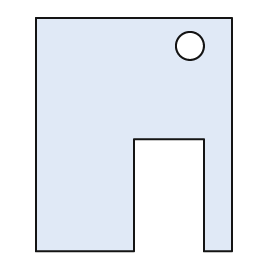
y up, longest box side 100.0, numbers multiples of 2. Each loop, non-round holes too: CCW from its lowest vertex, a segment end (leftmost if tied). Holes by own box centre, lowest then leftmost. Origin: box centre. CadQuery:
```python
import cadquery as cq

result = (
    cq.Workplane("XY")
    .moveTo(-42.0, -50.0)
    .lineTo(0.0, -50.0)
    .lineTo(0.0, -2.0)
    .lineTo(30.0, -2.0)
    .lineTo(30.0, -50.0)
    .lineTo(42.0, -50.0)
    .lineTo(42.0, 50.0)
    .lineTo(-42.0, 50.0)
    .close()
    .moveTo(24.0, 38.0)
    .circle(6.0)
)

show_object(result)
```